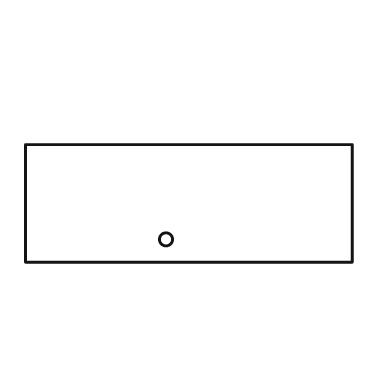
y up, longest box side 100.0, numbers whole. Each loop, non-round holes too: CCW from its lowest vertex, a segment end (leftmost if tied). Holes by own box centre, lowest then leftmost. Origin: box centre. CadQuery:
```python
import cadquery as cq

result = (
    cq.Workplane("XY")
    .moveTo(-50.0, -18.0)
    .lineTo(50.0, -18.0)
    .lineTo(50.0, 18.0)
    .lineTo(-50.0, 18.0)
    .close()
    .moveTo(-7.0, -11.0)
    .circle(2.0)
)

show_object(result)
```